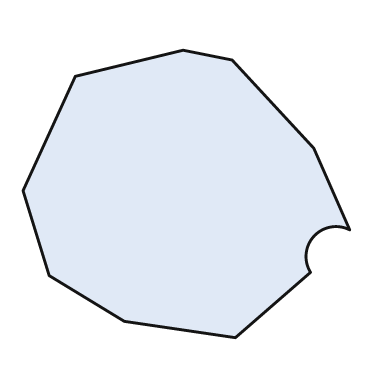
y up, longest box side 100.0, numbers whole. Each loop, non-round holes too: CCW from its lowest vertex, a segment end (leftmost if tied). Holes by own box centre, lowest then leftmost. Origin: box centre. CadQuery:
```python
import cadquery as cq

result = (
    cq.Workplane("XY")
    .moveTo(15.0, -44.0)
    .lineTo(38.0, -24.0)
    .threePointArc((39.0, -13.0), (50.0, -11.0))
    .lineTo(39.0, 14.0)
    .lineTo(14.0, 41.0)
    .lineTo(-1.0, 44.0)
    .lineTo(-34.0, 36.0)
    .lineTo(-50.0, 1.0)
    .lineTo(-42.0, -25.0)
    .lineTo(-19.0, -39.0)
    .close()
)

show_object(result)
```